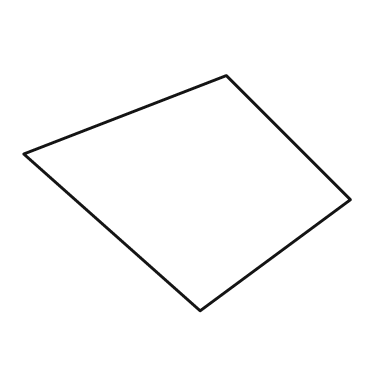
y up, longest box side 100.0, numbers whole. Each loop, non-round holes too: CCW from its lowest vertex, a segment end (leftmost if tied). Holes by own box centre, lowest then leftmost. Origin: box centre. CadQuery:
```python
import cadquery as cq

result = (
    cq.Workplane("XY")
    .moveTo(4.0, -36.0)
    .lineTo(50.0, -2.0)
    .lineTo(12.0, 36.0)
    .lineTo(-50.0, 12.0)
    .close()
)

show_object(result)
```